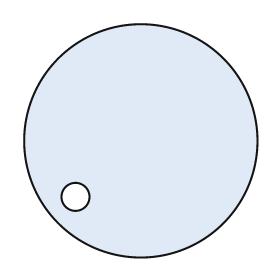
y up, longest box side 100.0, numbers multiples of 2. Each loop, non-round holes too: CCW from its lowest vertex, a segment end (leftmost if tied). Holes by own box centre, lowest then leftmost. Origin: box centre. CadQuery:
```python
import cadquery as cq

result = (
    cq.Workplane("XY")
    .moveTo(0.0, 0.0)
    .circle(50.0)
    .moveTo(-28.0, -24.0)
    .circle(6.0)
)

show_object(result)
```